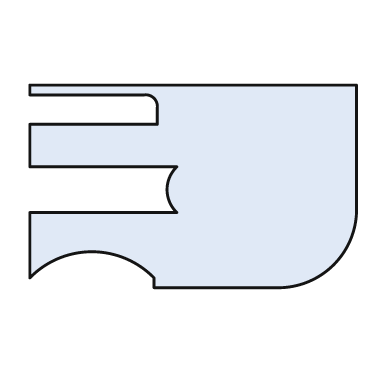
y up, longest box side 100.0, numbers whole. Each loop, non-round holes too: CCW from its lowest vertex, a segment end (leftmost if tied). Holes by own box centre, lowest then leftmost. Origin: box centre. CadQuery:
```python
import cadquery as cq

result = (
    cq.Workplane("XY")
    .moveTo(-12.0, -31.0)
    .lineTo(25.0, -31.0)
    .threePointArc((43.0, -24.0), (50.0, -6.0))
    .lineTo(50.0, 31.0)
    .lineTo(-50.0, 31.0)
    .lineTo(-50.0, 28.0)
    .lineTo(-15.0, 28.0)
    .threePointArc((-12.0, 27.0), (-11.0, 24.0))
    .lineTo(-11.0, 19.0)
    .lineTo(-50.0, 19.0)
    .lineTo(-50.0, 6.0)
    .lineTo(-5.0, 6.0)
    .threePointArc((-8.0, -1.0), (-5.0, -8.0))
    .lineTo(-50.0, -8.0)
    .lineTo(-50.0, -28.0)
    .threePointArc((-31.0, -20.0), (-12.0, -28.0))
    .close()
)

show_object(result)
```